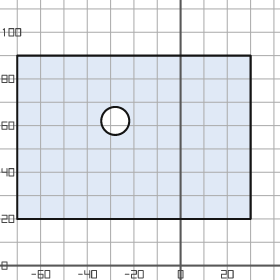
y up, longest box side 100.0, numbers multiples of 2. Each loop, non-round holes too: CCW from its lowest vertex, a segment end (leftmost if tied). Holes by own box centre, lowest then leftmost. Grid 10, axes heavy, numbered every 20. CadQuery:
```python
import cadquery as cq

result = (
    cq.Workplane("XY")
    .moveTo(-70.0, 20.0)
    .lineTo(30.0, 20.0)
    .lineTo(30.0, 90.0)
    .lineTo(-70.0, 90.0)
    .close()
    .moveTo(-28.0, 62.0)
    .circle(6.0)
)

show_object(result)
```